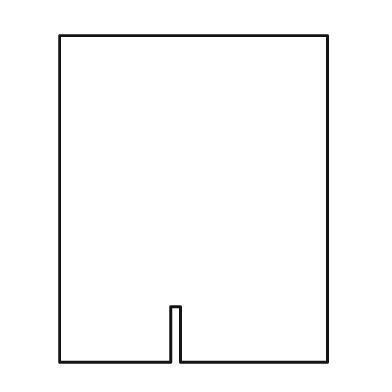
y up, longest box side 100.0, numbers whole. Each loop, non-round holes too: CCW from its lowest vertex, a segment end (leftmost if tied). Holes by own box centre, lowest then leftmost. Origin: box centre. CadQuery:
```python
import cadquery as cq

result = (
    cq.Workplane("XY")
    .moveTo(-41.0, -50.0)
    .lineTo(-7.0, -50.0)
    .lineTo(-7.0, -33.0)
    .lineTo(-4.0, -33.0)
    .lineTo(-4.0, -50.0)
    .lineTo(41.0, -50.0)
    .lineTo(41.0, 50.0)
    .lineTo(-41.0, 50.0)
    .close()
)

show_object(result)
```